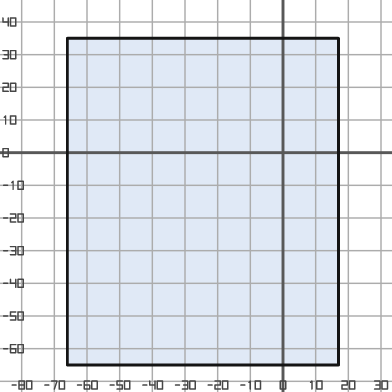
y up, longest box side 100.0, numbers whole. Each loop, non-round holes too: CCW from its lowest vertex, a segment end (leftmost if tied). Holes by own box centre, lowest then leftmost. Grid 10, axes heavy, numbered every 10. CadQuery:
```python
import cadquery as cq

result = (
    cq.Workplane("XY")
    .moveTo(-66.0, -65.0)
    .lineTo(17.0, -65.0)
    .lineTo(17.0, 35.0)
    .lineTo(-66.0, 35.0)
    .close()
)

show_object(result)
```